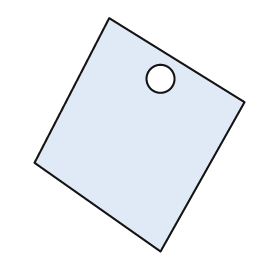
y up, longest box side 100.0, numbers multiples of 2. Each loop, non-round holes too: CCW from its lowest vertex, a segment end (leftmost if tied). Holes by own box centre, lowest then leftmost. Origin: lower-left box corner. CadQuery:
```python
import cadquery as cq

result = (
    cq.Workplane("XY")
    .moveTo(54.0, 0.0)
    .lineTo(90.0, 64.0)
    .lineTo(32.0, 100.0)
    .lineTo(0.0, 38.0)
    .close()
    .moveTo(54.0, 74.0)
    .circle(6.0)
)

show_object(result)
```